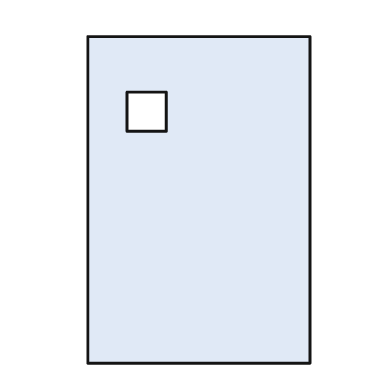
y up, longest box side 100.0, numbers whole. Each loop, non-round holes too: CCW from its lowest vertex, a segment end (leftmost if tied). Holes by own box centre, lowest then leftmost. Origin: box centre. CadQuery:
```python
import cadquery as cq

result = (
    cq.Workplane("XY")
    .moveTo(-34.0, -50.0)
    .lineTo(34.0, -50.0)
    .lineTo(34.0, 50.0)
    .lineTo(-34.0, 50.0)
    .close()
    .moveTo(-22.0, 21.0)
    .lineTo(-10.0, 21.0)
    .lineTo(-10.0, 33.0)
    .lineTo(-22.0, 33.0)
    .close()
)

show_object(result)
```